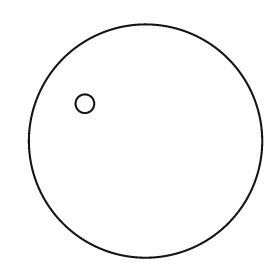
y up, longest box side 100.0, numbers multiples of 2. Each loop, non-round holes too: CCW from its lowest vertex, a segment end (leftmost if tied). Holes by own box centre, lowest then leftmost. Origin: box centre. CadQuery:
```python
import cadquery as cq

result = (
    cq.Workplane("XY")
    .moveTo(0.0, 0.0)
    .circle(50.0)
    .moveTo(-26.0, 16.0)
    .circle(4.0)
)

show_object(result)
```